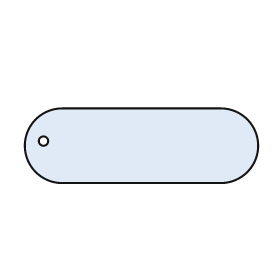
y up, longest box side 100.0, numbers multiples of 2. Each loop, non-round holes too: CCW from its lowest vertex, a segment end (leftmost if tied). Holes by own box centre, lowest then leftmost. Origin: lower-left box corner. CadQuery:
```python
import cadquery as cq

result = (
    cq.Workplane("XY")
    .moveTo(16.0, 0.0)
    .lineTo(84.0, 0.0)
    .threePointArc((100.0, 16.0), (84.0, 32.0))
    .lineTo(16.0, 32.0)
    .threePointArc((0.0, 16.0), (16.0, 0.0))
    .close()
    .moveTo(8.0, 18.0)
    .circle(2.0)
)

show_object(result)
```